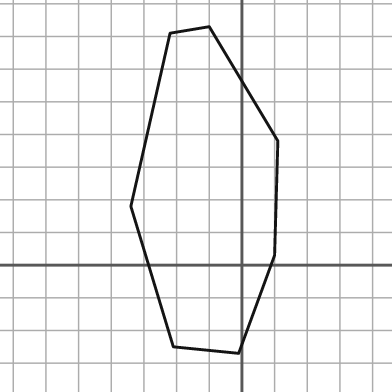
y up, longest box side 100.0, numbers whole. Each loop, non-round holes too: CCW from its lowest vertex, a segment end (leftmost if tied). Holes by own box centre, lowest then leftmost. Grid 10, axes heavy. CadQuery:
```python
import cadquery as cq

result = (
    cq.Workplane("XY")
    .moveTo(-1.0, -27.0)
    .lineTo(10.0, 3.0)
    .lineTo(11.0, 38.0)
    .lineTo(-10.0, 73.0)
    .lineTo(-22.0, 71.0)
    .lineTo(-34.0, 18.0)
    .lineTo(-21.0, -25.0)
    .close()
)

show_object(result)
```